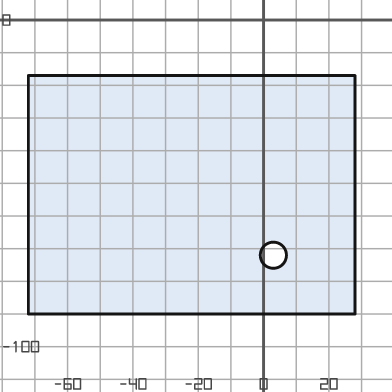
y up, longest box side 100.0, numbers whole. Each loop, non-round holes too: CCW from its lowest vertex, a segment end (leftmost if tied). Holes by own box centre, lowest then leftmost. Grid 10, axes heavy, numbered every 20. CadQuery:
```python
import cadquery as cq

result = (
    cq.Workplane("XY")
    .moveTo(-72.0, -90.0)
    .lineTo(28.0, -90.0)
    .lineTo(28.0, -17.0)
    .lineTo(-72.0, -17.0)
    .close()
    .moveTo(3.0, -72.0)
    .circle(4.0)
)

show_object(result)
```